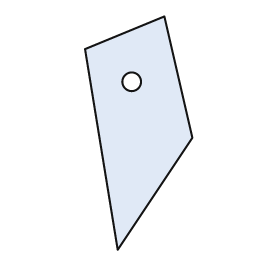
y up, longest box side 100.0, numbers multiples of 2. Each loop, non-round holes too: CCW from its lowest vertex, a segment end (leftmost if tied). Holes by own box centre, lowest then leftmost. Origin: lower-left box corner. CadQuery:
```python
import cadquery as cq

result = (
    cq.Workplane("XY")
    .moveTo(14.0, 0.0)
    .lineTo(46.0, 48.0)
    .lineTo(34.0, 100.0)
    .lineTo(0.0, 86.0)
    .close()
    .moveTo(20.0, 72.0)
    .circle(4.0)
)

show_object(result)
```